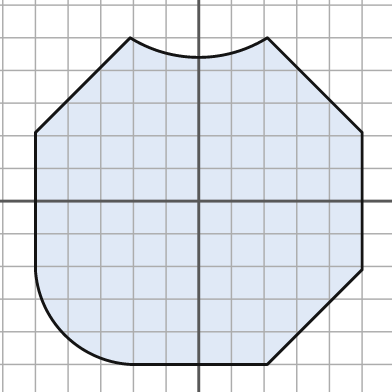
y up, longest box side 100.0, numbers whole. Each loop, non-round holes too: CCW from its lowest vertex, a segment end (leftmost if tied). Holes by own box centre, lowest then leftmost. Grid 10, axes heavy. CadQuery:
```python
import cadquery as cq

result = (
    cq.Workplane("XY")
    .moveTo(-21.0, -50.0)
    .lineTo(21.0, -50.0)
    .lineTo(50.0, -21.0)
    .lineTo(50.0, 21.0)
    .lineTo(21.0, 50.0)
    .threePointArc((0.0, 44.0), (-21.0, 50.0))
    .lineTo(-50.0, 21.0)
    .lineTo(-50.0, -21.0)
    .threePointArc((-41.0, -41.0), (-21.0, -50.0))
    .close()
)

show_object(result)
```